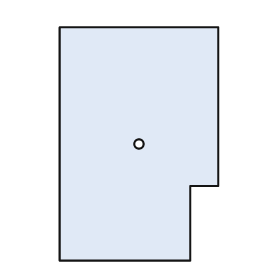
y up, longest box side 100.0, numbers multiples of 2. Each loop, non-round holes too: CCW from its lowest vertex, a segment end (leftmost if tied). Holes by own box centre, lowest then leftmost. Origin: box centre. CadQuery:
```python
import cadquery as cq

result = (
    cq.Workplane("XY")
    .moveTo(-34.0, -50.0)
    .lineTo(22.0, -50.0)
    .lineTo(22.0, -18.0)
    .lineTo(34.0, -18.0)
    .lineTo(34.0, 50.0)
    .lineTo(-34.0, 50.0)
    .close()
    .moveTo(0.0, 0.0)
    .circle(2.0)
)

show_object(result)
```